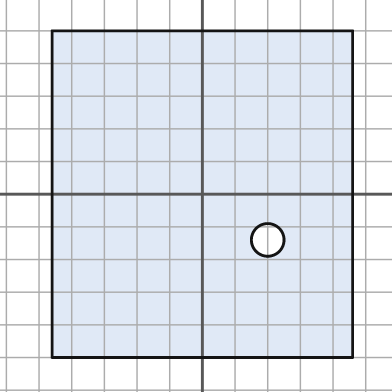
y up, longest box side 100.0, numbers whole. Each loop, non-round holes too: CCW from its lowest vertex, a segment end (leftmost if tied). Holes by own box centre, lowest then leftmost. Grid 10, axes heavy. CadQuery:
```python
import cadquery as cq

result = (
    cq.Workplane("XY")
    .moveTo(-46.0, -50.0)
    .lineTo(46.0, -50.0)
    .lineTo(46.0, 50.0)
    .lineTo(-46.0, 50.0)
    .close()
    .moveTo(20.0, -14.0)
    .circle(5.0)
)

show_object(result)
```